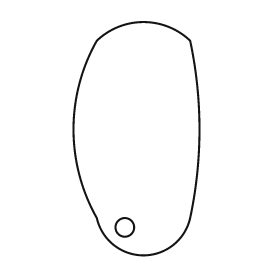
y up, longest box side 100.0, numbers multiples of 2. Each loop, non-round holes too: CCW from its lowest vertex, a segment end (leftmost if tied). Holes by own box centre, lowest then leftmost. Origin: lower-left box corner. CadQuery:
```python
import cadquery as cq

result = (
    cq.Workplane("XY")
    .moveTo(10.0, 16.0)
    .threePointArc((30.0, 0.0), (50.0, 16.0))
    .threePointArc((54.0, 54.0), (50.0, 92.0))
    .threePointArc((30.0, 100.0), (10.0, 92.0))
    .threePointArc((0.0, 54.0), (10.0, 16.0))
    .close()
    .moveTo(22.0, 12.0)
    .circle(4.0)
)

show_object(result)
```